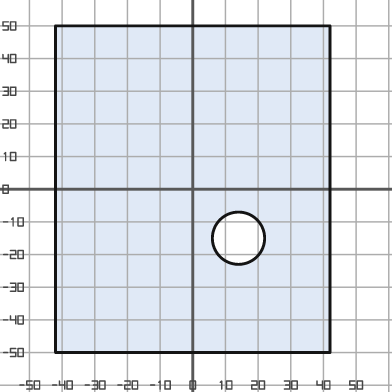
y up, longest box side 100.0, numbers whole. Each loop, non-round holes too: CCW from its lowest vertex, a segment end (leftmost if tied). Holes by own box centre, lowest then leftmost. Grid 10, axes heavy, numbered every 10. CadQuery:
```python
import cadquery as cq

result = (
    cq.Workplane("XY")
    .moveTo(-42.0, -50.0)
    .lineTo(42.0, -50.0)
    .lineTo(42.0, 50.0)
    .lineTo(-42.0, 50.0)
    .close()
    .moveTo(14.0, -15.0)
    .circle(8.0)
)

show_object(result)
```